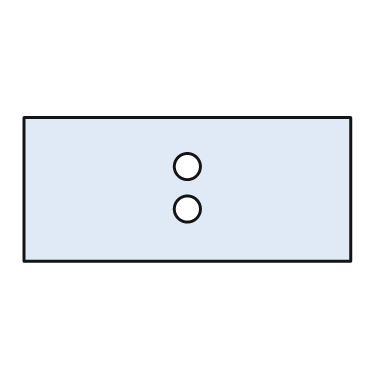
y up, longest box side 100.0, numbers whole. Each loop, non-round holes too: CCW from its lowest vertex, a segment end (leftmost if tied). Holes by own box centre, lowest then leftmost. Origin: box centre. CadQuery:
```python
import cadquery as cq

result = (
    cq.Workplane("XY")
    .moveTo(-50.0, -22.0)
    .lineTo(50.0, -22.0)
    .lineTo(50.0, 22.0)
    .lineTo(-50.0, 22.0)
    .close()
    .moveTo(0.0, -6.0)
    .circle(4.0)
    .moveTo(0.0, 7.0)
    .circle(4.0)
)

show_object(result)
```